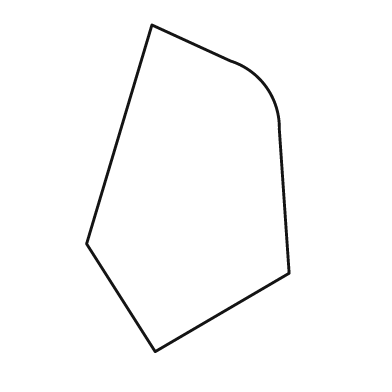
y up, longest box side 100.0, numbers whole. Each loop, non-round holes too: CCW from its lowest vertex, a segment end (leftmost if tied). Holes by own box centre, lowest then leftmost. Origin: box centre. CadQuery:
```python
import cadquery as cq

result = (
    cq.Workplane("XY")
    .moveTo(-10.0, -50.0)
    .lineTo(31.0, -26.0)
    .lineTo(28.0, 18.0)
    .threePointArc((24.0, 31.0), (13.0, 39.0))
    .lineTo(-11.0, 50.0)
    .lineTo(-31.0, -17.0)
    .close()
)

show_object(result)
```